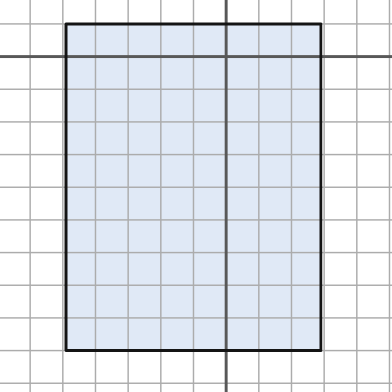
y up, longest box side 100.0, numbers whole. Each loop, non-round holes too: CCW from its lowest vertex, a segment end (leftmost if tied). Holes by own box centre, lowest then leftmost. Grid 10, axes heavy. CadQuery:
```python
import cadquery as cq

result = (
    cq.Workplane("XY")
    .moveTo(-49.0, -90.0)
    .lineTo(29.0, -90.0)
    .lineTo(29.0, 10.0)
    .lineTo(-49.0, 10.0)
    .close()
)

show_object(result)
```